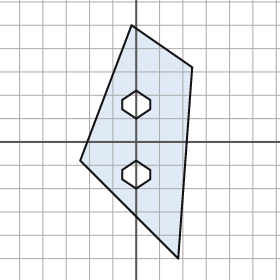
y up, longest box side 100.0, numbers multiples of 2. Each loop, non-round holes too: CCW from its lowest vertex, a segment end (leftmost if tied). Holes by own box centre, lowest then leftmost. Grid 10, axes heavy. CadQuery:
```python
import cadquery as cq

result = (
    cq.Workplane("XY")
    .moveTo(18.0, -50.0)
    .lineTo(24.0, 32.0)
    .lineTo(-2.0, 50.0)
    .lineTo(-24.0, -8.0)
    .close()
    .moveTo(0.0, -20.0)
    .lineTo(6.0, -16.0)
    .lineTo(6.0, -12.0)
    .lineTo(0.0, -8.0)
    .lineTo(-6.0, -12.0)
    .lineTo(-6.0, -16.0)
    .close()
    .moveTo(0.0, 10.0)
    .lineTo(6.0, 14.0)
    .lineTo(6.0, 18.0)
    .lineTo(0.0, 22.0)
    .lineTo(-6.0, 18.0)
    .lineTo(-6.0, 14.0)
    .close()
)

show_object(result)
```